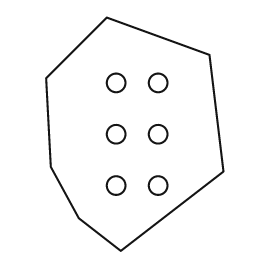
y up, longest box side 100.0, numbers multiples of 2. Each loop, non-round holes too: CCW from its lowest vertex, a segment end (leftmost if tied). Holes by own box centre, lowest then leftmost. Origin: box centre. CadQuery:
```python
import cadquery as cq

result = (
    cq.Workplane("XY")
    .moveTo(-6.0, -50.0)
    .lineTo(38.0, -16.0)
    .lineTo(32.0, 34.0)
    .lineTo(-12.0, 50.0)
    .lineTo(-38.0, 24.0)
    .lineTo(-36.0, -14.0)
    .lineTo(-24.0, -36.0)
    .close()
    .moveTo(-8.0, -22.0)
    .circle(4.0)
    .moveTo(10.0, -22.0)
    .circle(4.0)
    .moveTo(-8.0, 0.0)
    .circle(4.0)
    .moveTo(10.0, 0.0)
    .circle(4.0)
    .moveTo(-8.0, 22.0)
    .circle(4.0)
    .moveTo(10.0, 22.0)
    .circle(4.0)
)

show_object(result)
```